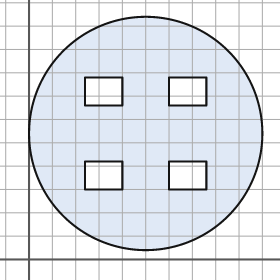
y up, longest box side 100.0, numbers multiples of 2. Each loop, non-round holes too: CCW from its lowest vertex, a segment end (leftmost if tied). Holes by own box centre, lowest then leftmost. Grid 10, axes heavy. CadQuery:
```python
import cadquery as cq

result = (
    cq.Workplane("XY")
    .moveTo(50.0, 54.0)
    .circle(50.0)
    .moveTo(24.0, 30.0)
    .lineTo(40.0, 30.0)
    .lineTo(40.0, 42.0)
    .lineTo(24.0, 42.0)
    .close()
    .moveTo(60.0, 30.0)
    .lineTo(76.0, 30.0)
    .lineTo(76.0, 42.0)
    .lineTo(60.0, 42.0)
    .close()
    .moveTo(24.0, 66.0)
    .lineTo(40.0, 66.0)
    .lineTo(40.0, 78.0)
    .lineTo(24.0, 78.0)
    .close()
    .moveTo(60.0, 66.0)
    .lineTo(76.0, 66.0)
    .lineTo(76.0, 78.0)
    .lineTo(60.0, 78.0)
    .close()
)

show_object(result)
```